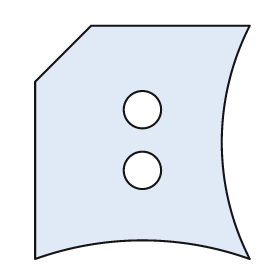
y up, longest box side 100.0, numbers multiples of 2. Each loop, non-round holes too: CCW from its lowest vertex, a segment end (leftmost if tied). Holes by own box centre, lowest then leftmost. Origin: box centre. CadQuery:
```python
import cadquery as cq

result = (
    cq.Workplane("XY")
    .moveTo(-46.0, -50.0)
    .threePointArc((0.0, -42.0), (46.0, -50.0))
    .threePointArc((34.0, 0.0), (46.0, 50.0))
    .lineTo(-22.0, 50.0)
    .lineTo(-46.0, 26.0)
    .close()
    .moveTo(0.0, -12.0)
    .circle(8.0)
    .moveTo(0.0, 14.0)
    .circle(8.0)
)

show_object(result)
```